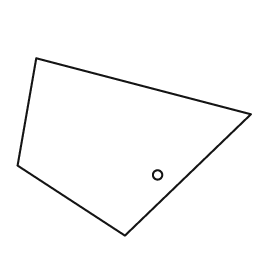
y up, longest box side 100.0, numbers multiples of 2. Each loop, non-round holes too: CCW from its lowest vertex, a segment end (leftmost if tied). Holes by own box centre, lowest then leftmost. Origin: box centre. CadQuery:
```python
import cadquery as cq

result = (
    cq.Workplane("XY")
    .moveTo(-4.0, -38.0)
    .lineTo(50.0, 14.0)
    .lineTo(-42.0, 38.0)
    .lineTo(-50.0, -8.0)
    .close()
    .moveTo(10.0, -12.0)
    .circle(2.0)
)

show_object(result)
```